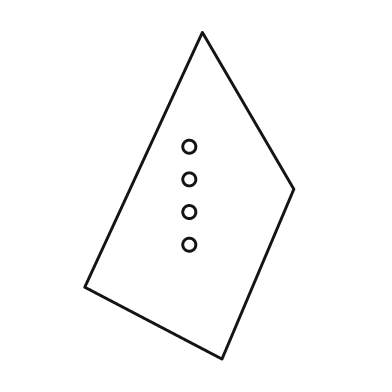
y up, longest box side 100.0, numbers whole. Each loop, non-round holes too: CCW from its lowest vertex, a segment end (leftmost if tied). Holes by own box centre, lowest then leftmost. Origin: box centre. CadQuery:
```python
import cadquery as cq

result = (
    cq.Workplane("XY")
    .moveTo(10.0, -50.0)
    .lineTo(32.0, 2.0)
    .lineTo(4.0, 50.0)
    .lineTo(-32.0, -28.0)
    .close()
    .moveTo(0.0, -15.0)
    .circle(2.0)
    .moveTo(0.0, -5.0)
    .circle(2.0)
    .moveTo(0.0, 5.0)
    .circle(2.0)
    .moveTo(0.0, 15.0)
    .circle(2.0)
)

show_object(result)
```